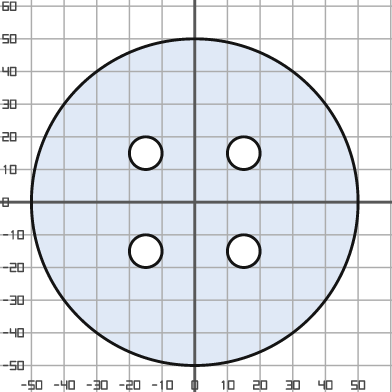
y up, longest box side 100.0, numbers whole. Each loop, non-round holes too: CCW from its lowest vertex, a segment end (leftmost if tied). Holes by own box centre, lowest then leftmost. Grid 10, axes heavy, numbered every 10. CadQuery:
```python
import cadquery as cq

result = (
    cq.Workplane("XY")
    .moveTo(0.0, 0.0)
    .circle(50.0)
    .moveTo(-15.0, -15.0)
    .circle(5.0)
    .moveTo(15.0, -15.0)
    .circle(5.0)
    .moveTo(-15.0, 15.0)
    .circle(5.0)
    .moveTo(15.0, 15.0)
    .circle(5.0)
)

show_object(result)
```